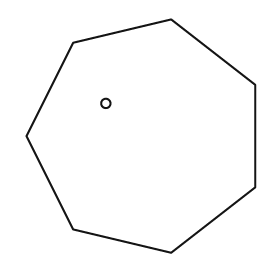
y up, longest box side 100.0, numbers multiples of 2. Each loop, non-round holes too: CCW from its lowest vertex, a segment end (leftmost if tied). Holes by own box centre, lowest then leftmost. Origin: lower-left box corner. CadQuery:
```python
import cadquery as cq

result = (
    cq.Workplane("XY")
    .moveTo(62.0, 0.0)
    .lineTo(98.0, 28.0)
    .lineTo(98.0, 72.0)
    .lineTo(62.0, 100.0)
    .lineTo(20.0, 90.0)
    .lineTo(0.0, 50.0)
    .lineTo(20.0, 10.0)
    .close()
    .moveTo(34.0, 64.0)
    .circle(2.0)
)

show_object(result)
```